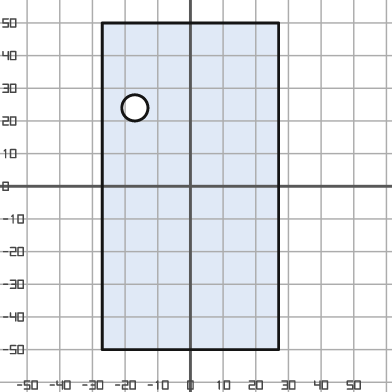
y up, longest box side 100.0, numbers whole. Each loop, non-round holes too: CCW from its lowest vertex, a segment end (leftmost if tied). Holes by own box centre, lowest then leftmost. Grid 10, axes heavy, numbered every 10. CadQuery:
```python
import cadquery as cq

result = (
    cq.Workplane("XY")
    .moveTo(-27.0, -50.0)
    .lineTo(27.0, -50.0)
    .lineTo(27.0, 50.0)
    .lineTo(-27.0, 50.0)
    .close()
    .moveTo(-17.0, 24.0)
    .circle(4.0)
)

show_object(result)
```